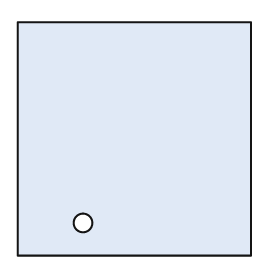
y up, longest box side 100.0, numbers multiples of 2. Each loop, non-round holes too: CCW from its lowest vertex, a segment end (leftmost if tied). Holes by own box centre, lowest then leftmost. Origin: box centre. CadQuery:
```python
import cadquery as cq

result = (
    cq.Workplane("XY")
    .moveTo(-50.0, -50.0)
    .lineTo(50.0, -50.0)
    .lineTo(50.0, 50.0)
    .lineTo(-50.0, 50.0)
    .close()
    .moveTo(-22.0, -36.0)
    .circle(4.0)
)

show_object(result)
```